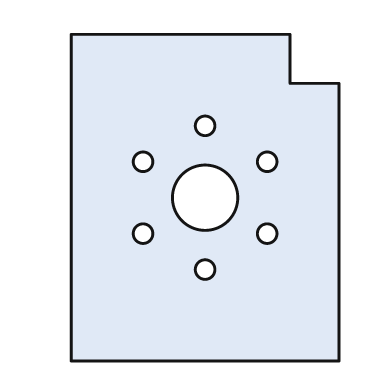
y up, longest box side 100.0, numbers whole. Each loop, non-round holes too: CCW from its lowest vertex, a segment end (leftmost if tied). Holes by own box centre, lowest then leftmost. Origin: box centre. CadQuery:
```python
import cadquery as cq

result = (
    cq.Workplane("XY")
    .moveTo(-41.0, -50.0)
    .lineTo(41.0, -50.0)
    .lineTo(41.0, 35.0)
    .lineTo(26.0, 35.0)
    .lineTo(26.0, 50.0)
    .lineTo(-41.0, 50.0)
    .close()
    .moveTo(0.0, -22.0)
    .circle(3.0)
    .moveTo(-19.0, -11.0)
    .circle(3.0)
    .moveTo(19.0, -11.0)
    .circle(3.0)
    .moveTo(0.0, 0.0)
    .circle(10.0)
    .moveTo(-19.0, 11.0)
    .circle(3.0)
    .moveTo(19.0, 11.0)
    .circle(3.0)
    .moveTo(0.0, 22.0)
    .circle(3.0)
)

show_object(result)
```